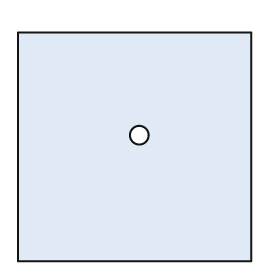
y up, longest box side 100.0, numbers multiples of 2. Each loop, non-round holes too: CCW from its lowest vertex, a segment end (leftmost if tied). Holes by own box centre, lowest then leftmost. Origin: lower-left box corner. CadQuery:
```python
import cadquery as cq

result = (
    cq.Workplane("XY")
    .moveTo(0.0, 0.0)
    .lineTo(100.0, 0.0)
    .lineTo(100.0, 98.0)
    .lineTo(0.0, 98.0)
    .close()
    .moveTo(52.0, 54.0)
    .circle(4.0)
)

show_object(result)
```